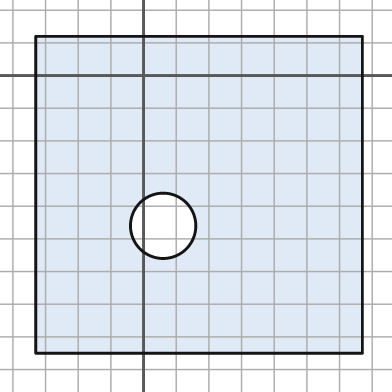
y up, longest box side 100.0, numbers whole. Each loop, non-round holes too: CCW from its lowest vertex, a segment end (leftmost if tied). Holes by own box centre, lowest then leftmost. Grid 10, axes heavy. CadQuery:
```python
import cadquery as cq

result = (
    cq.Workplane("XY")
    .moveTo(-33.0, -85.0)
    .lineTo(67.0, -85.0)
    .lineTo(67.0, 12.0)
    .lineTo(-33.0, 12.0)
    .close()
    .moveTo(6.0, -46.0)
    .circle(10.0)
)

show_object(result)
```